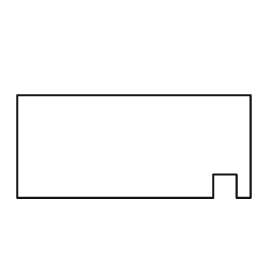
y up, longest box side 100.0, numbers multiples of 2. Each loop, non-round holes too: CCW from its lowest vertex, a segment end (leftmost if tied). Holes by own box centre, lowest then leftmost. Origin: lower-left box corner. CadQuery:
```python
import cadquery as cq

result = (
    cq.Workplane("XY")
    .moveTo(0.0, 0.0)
    .lineTo(84.0, 0.0)
    .lineTo(84.0, 10.0)
    .lineTo(94.0, 10.0)
    .lineTo(94.0, 0.0)
    .lineTo(100.0, 0.0)
    .lineTo(100.0, 44.0)
    .lineTo(0.0, 44.0)
    .close()
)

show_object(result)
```